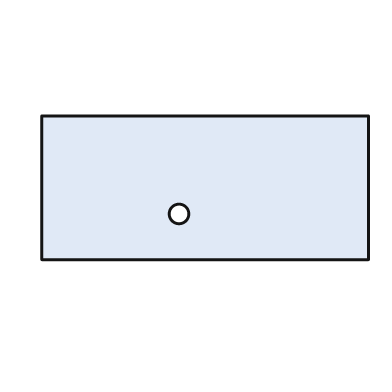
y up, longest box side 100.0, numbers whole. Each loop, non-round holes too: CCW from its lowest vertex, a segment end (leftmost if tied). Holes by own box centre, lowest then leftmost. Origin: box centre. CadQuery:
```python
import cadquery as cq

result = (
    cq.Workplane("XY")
    .moveTo(-50.0, -22.0)
    .lineTo(50.0, -22.0)
    .lineTo(50.0, 22.0)
    .lineTo(-50.0, 22.0)
    .close()
    .moveTo(-8.0, -8.0)
    .circle(3.0)
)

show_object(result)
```